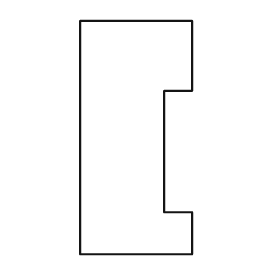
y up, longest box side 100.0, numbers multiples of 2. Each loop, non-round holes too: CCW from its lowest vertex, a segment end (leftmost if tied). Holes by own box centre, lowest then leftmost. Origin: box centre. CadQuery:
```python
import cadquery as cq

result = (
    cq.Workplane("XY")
    .moveTo(-24.0, -50.0)
    .lineTo(24.0, -50.0)
    .lineTo(24.0, -32.0)
    .lineTo(12.0, -32.0)
    .lineTo(12.0, 20.0)
    .lineTo(24.0, 20.0)
    .lineTo(24.0, 50.0)
    .lineTo(-24.0, 50.0)
    .close()
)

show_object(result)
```